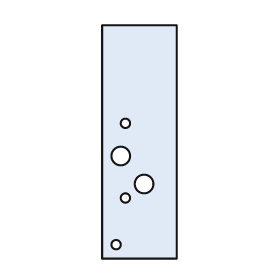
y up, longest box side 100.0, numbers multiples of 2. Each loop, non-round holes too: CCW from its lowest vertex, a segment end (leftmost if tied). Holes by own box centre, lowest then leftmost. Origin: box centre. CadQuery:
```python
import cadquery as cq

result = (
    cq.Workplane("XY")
    .moveTo(-16.0, -50.0)
    .lineTo(16.0, -50.0)
    .lineTo(16.0, 50.0)
    .lineTo(-16.0, 50.0)
    .close()
    .moveTo(-10.0, -44.0)
    .circle(2.0)
    .moveTo(-6.0, -24.0)
    .circle(2.0)
    .moveTo(2.0, -18.0)
    .circle(4.0)
    .moveTo(-8.0, -6.0)
    .circle(4.0)
    .moveTo(-6.0, 8.0)
    .circle(2.0)
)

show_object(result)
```